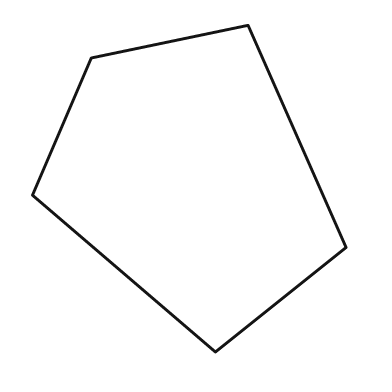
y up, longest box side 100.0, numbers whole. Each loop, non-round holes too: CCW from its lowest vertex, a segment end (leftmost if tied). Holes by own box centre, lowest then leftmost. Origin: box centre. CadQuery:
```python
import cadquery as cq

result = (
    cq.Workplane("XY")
    .moveTo(8.0, -50.0)
    .lineTo(48.0, -18.0)
    .lineTo(18.0, 50.0)
    .lineTo(-30.0, 40.0)
    .lineTo(-48.0, -2.0)
    .close()
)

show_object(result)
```